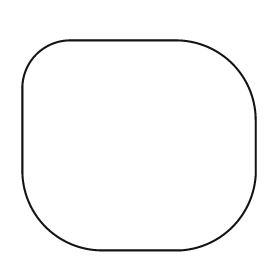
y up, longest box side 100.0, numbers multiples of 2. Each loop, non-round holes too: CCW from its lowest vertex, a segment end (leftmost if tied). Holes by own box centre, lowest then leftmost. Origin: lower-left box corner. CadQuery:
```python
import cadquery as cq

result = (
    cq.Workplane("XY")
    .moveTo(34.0, 0.0)
    .lineTo(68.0, 0.0)
    .threePointArc((90.0, 10.0), (100.0, 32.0))
    .lineTo(100.0, 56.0)
    .threePointArc((90.0, 80.0), (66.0, 90.0))
    .lineTo(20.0, 90.0)
    .threePointArc((6.0, 84.0), (0.0, 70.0))
    .lineTo(0.0, 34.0)
    .threePointArc((10.0, 10.0), (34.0, 0.0))
    .close()
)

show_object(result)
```